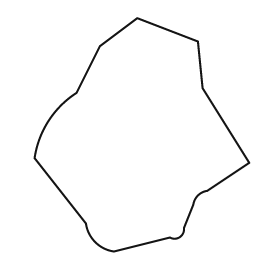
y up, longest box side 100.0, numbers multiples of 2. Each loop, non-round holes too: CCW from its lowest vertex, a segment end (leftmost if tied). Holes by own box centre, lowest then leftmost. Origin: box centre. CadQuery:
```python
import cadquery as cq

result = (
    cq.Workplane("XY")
    .moveTo(-12.0, -50.0)
    .lineTo(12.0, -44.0)
    .threePointArc((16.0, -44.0), (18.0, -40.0))
    .lineTo(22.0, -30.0)
    .threePointArc((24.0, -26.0), (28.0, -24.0))
    .lineTo(46.0, -12.0)
    .lineTo(26.0, 20.0)
    .lineTo(24.0, 40.0)
    .lineTo(-2.0, 50.0)
    .lineTo(-18.0, 38.0)
    .lineTo(-28.0, 18.0)
    .threePointArc((-40.0, 6.0), (-46.0, -10.0))
    .lineTo(-24.0, -38.0)
    .threePointArc((-20.0, -46.0), (-12.0, -50.0))
    .close()
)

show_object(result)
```